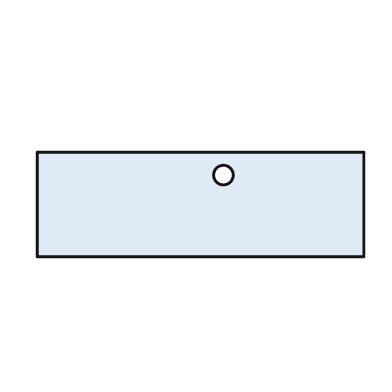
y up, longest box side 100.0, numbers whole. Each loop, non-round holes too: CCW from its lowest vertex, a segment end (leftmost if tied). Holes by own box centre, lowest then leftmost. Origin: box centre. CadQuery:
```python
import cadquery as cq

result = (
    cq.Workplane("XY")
    .moveTo(-50.0, -16.0)
    .lineTo(50.0, -16.0)
    .lineTo(50.0, 16.0)
    .lineTo(-50.0, 16.0)
    .close()
    .moveTo(7.0, 9.0)
    .circle(3.0)
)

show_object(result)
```